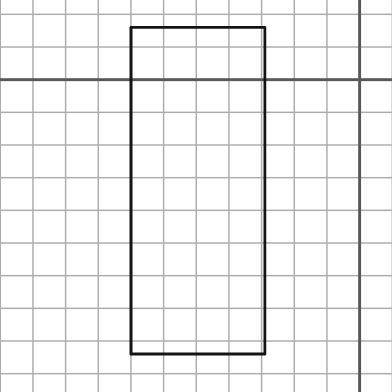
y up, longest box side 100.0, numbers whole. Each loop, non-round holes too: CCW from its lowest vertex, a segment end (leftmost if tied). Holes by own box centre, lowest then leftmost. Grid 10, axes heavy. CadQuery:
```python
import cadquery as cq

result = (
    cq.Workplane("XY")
    .moveTo(-70.0, -84.0)
    .lineTo(-29.0, -84.0)
    .lineTo(-29.0, 16.0)
    .lineTo(-70.0, 16.0)
    .close()
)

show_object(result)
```